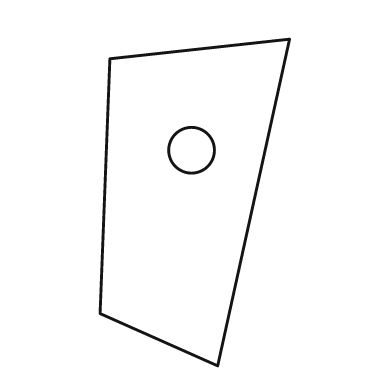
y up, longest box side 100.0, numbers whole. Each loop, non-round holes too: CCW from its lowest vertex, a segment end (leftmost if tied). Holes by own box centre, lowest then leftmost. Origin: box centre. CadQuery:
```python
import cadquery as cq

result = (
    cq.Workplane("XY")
    .moveTo(7.0, -50.0)
    .lineTo(29.0, 50.0)
    .lineTo(-26.0, 44.0)
    .lineTo(-29.0, -34.0)
    .close()
    .moveTo(-1.0, 16.0)
    .circle(7.0)
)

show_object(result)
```